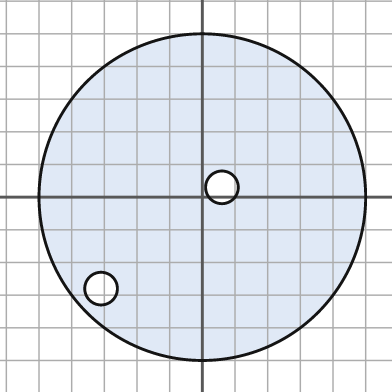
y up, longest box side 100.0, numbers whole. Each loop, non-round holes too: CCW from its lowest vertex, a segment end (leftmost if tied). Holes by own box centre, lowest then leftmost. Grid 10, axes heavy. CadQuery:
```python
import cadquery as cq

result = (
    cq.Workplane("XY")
    .moveTo(0.0, 0.0)
    .circle(50.0)
    .moveTo(-31.0, -28.0)
    .circle(5.0)
    .moveTo(6.0, 3.0)
    .circle(5.0)
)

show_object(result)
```